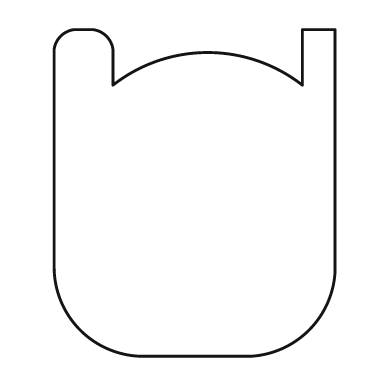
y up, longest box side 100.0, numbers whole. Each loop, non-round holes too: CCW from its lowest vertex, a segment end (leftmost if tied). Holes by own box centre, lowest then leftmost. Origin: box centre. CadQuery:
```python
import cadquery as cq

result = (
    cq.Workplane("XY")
    .moveTo(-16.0, -50.0)
    .lineTo(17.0, -50.0)
    .threePointArc((35.0, -42.0), (43.0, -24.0))
    .lineTo(43.0, 50.0)
    .lineTo(33.0, 50.0)
    .lineTo(33.0, 33.0)
    .threePointArc((4.0, 43.0), (-25.0, 33.0))
    .lineTo(-25.0, 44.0)
    .threePointArc((-27.0, 48.0), (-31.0, 50.0))
    .lineTo(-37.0, 50.0)
    .threePointArc((-41.0, 48.0), (-43.0, 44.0))
    .lineTo(-43.0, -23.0)
    .threePointArc((-35.0, -42.0), (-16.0, -50.0))
    .close()
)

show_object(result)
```